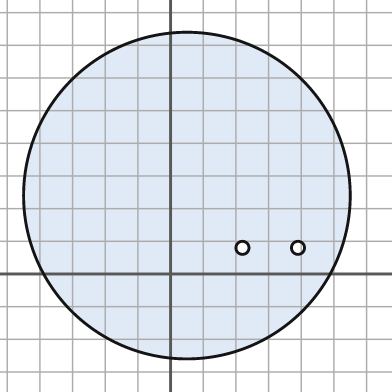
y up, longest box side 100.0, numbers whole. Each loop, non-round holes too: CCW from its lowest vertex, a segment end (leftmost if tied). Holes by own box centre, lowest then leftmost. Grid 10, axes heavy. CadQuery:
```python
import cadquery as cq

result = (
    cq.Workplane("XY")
    .moveTo(5.0, 24.0)
    .circle(50.0)
    .moveTo(22.0, 8.0)
    .circle(2.0)
    .moveTo(39.0, 8.0)
    .circle(2.0)
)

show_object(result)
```